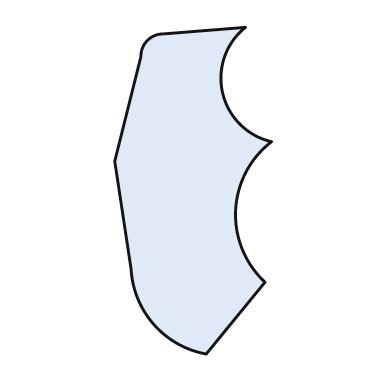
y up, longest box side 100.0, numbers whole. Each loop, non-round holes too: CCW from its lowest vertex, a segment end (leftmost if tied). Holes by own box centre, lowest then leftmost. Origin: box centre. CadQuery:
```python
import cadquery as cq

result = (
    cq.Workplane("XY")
    .moveTo(4.0, -50.0)
    .lineTo(22.0, -28.0)
    .threePointArc((13.0, -6.0), (24.0, 15.0))
    .threePointArc((9.0, 30.0), (16.0, 50.0))
    .lineTo(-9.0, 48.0)
    .threePointArc((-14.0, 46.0), (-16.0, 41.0))
    .lineTo(-24.0, 9.0)
    .lineTo(-19.0, -24.0)
    .threePointArc((-12.0, -41.0), (4.0, -50.0))
    .close()
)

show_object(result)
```